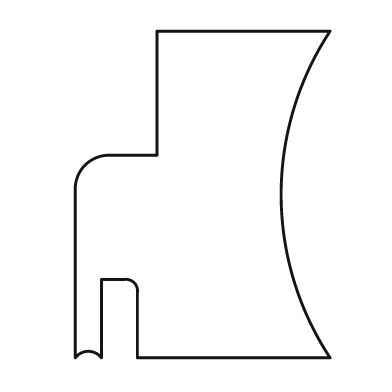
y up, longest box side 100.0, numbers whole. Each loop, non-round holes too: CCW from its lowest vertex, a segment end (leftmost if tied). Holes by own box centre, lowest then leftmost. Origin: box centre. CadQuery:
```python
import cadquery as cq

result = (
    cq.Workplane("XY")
    .moveTo(-39.0, -50.0)
    .threePointArc((-35.0, -48.0), (-31.0, -50.0))
    .lineTo(-31.0, -26.0)
    .lineTo(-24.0, -26.0)
    .threePointArc((-21.0, -27.0), (-20.0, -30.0))
    .lineTo(-20.0, -50.0)
    .lineTo(39.0, -50.0)
    .threePointArc((24.0, 0.0), (39.0, 50.0))
    .lineTo(-14.0, 50.0)
    .lineTo(-14.0, 12.0)
    .lineTo(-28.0, 12.0)
    .threePointArc((-36.0, 9.0), (-39.0, 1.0))
    .close()
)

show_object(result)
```